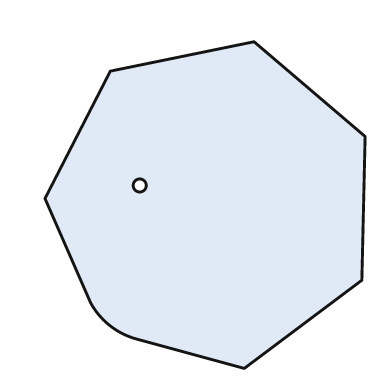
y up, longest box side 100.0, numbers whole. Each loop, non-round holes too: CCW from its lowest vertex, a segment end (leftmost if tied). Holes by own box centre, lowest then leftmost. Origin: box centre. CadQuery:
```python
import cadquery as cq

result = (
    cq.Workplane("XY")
    .moveTo(12.0, -50.0)
    .lineTo(48.0, -23.0)
    .lineTo(49.0, 21.0)
    .lineTo(15.0, 50.0)
    .lineTo(-29.0, 41.0)
    .lineTo(-49.0, 2.0)
    .lineTo(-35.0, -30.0)
    .threePointArc((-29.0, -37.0), (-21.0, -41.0))
    .close()
    .moveTo(-20.0, 6.0)
    .circle(2.0)
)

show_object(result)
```